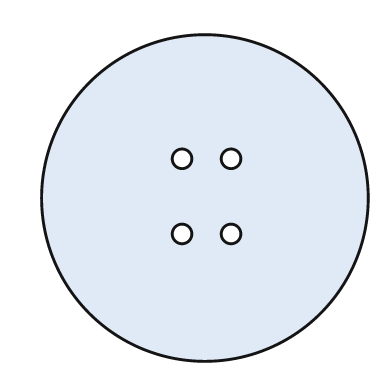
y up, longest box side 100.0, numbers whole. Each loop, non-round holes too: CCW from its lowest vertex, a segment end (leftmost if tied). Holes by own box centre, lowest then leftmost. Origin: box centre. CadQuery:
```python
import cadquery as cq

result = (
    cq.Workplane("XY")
    .moveTo(0.0, 0.0)
    .circle(50.0)
    .moveTo(-7.0, -11.0)
    .circle(3.0)
    .moveTo(8.0, -11.0)
    .circle(3.0)
    .moveTo(-7.0, 12.0)
    .circle(3.0)
    .moveTo(8.0, 12.0)
    .circle(3.0)
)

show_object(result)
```